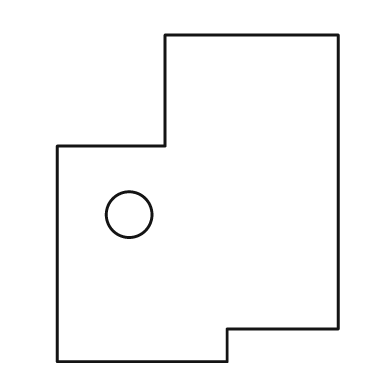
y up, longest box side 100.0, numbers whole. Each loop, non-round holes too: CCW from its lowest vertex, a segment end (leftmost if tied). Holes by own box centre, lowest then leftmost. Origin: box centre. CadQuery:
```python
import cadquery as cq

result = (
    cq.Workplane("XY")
    .moveTo(-43.0, -50.0)
    .lineTo(9.0, -50.0)
    .lineTo(9.0, -40.0)
    .lineTo(43.0, -40.0)
    .lineTo(43.0, 50.0)
    .lineTo(-10.0, 50.0)
    .lineTo(-10.0, 16.0)
    .lineTo(-43.0, 16.0)
    .close()
    .moveTo(-21.0, -5.0)
    .circle(7.0)
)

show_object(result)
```